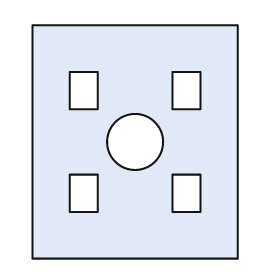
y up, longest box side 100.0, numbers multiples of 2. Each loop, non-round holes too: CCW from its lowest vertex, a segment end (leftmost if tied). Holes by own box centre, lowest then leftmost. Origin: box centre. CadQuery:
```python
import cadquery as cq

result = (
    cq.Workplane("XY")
    .moveTo(-44.0, -50.0)
    .lineTo(44.0, -50.0)
    .lineTo(44.0, 50.0)
    .lineTo(-44.0, 50.0)
    .close()
    .moveTo(-28.0, -30.0)
    .lineTo(-16.0, -30.0)
    .lineTo(-16.0, -14.0)
    .lineTo(-28.0, -14.0)
    .close()
    .moveTo(16.0, -30.0)
    .lineTo(28.0, -30.0)
    .lineTo(28.0, -14.0)
    .lineTo(16.0, -14.0)
    .close()
    .moveTo(0.0, 0.0)
    .circle(12.0)
    .moveTo(-28.0, 14.0)
    .lineTo(-16.0, 14.0)
    .lineTo(-16.0, 30.0)
    .lineTo(-28.0, 30.0)
    .close()
    .moveTo(16.0, 14.0)
    .lineTo(28.0, 14.0)
    .lineTo(28.0, 30.0)
    .lineTo(16.0, 30.0)
    .close()
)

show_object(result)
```